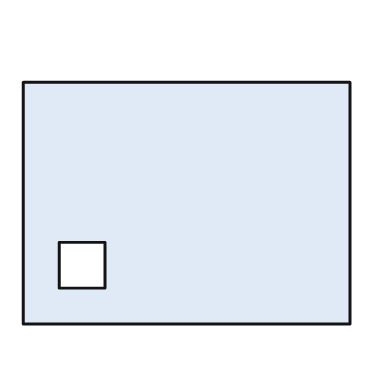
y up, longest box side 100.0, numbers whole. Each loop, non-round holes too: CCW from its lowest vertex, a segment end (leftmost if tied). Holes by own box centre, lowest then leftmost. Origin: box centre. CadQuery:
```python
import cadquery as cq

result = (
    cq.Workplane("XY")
    .moveTo(-50.0, -37.0)
    .lineTo(50.0, -37.0)
    .lineTo(50.0, 37.0)
    .lineTo(-50.0, 37.0)
    .close()
    .moveTo(-39.0, -26.0)
    .lineTo(-25.0, -26.0)
    .lineTo(-25.0, -12.0)
    .lineTo(-39.0, -12.0)
    .close()
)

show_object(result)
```